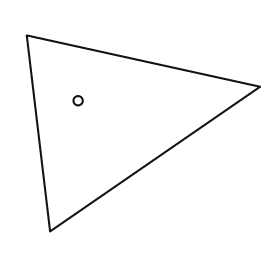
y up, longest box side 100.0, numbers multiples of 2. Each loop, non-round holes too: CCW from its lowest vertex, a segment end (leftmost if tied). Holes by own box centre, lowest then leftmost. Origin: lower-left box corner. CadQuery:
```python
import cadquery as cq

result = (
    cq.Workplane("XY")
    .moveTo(10.0, 0.0)
    .lineTo(100.0, 62.0)
    .lineTo(0.0, 84.0)
    .close()
    .moveTo(22.0, 56.0)
    .circle(2.0)
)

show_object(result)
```